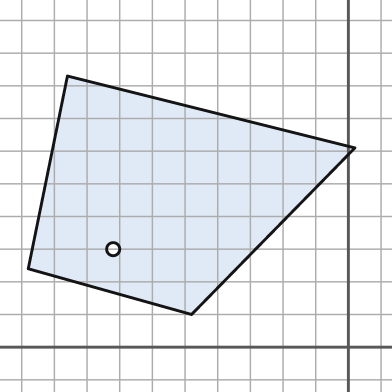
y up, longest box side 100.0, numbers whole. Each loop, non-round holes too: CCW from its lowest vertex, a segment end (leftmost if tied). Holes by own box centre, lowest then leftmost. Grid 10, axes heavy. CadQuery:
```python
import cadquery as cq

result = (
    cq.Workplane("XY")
    .moveTo(-48.0, 10.0)
    .lineTo(2.0, 61.0)
    .lineTo(-86.0, 83.0)
    .lineTo(-98.0, 24.0)
    .close()
    .moveTo(-72.0, 30.0)
    .circle(2.0)
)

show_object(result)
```